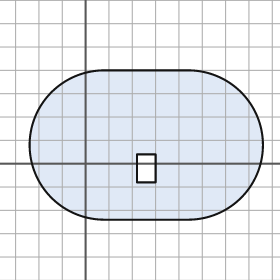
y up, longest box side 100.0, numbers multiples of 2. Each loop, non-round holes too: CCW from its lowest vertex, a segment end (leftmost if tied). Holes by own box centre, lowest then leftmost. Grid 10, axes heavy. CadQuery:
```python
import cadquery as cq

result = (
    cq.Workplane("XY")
    .moveTo(8.0, -24.0)
    .lineTo(44.0, -24.0)
    .threePointArc((76.0, 8.0), (44.0, 40.0))
    .lineTo(8.0, 40.0)
    .threePointArc((-24.0, 8.0), (8.0, -24.0))
    .close()
    .moveTo(22.0, -8.0)
    .lineTo(30.0, -8.0)
    .lineTo(30.0, 4.0)
    .lineTo(22.0, 4.0)
    .close()
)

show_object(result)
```